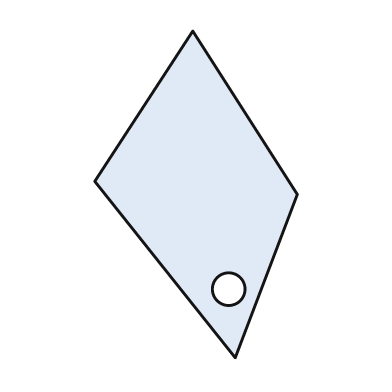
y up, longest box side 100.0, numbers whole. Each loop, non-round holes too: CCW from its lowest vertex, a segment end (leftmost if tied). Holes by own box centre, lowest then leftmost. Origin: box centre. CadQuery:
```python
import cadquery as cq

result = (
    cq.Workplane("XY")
    .moveTo(12.0, -50.0)
    .lineTo(31.0, 0.0)
    .lineTo(-1.0, 50.0)
    .lineTo(-31.0, 4.0)
    .close()
    .moveTo(10.0, -29.0)
    .circle(5.0)
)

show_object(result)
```